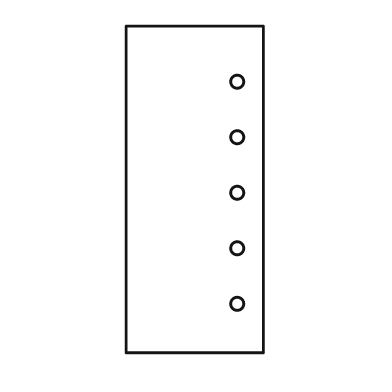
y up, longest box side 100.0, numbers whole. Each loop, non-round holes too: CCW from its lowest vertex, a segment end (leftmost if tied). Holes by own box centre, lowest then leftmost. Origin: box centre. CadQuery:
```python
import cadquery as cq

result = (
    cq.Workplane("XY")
    .moveTo(-21.0, -50.0)
    .lineTo(21.0, -50.0)
    .lineTo(21.0, 50.0)
    .lineTo(-21.0, 50.0)
    .close()
    .moveTo(13.0, -35.0)
    .circle(2.0)
    .moveTo(13.0, -18.0)
    .circle(2.0)
    .moveTo(13.0, -1.0)
    .circle(2.0)
    .moveTo(13.0, 16.0)
    .circle(2.0)
    .moveTo(13.0, 33.0)
    .circle(2.0)
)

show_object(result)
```